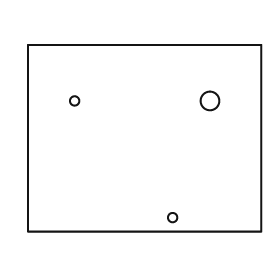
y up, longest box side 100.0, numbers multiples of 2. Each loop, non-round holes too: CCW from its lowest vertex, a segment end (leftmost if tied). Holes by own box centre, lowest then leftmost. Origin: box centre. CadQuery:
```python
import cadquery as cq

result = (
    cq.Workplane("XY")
    .moveTo(-50.0, -40.0)
    .lineTo(50.0, -40.0)
    .lineTo(50.0, 40.0)
    .lineTo(-50.0, 40.0)
    .close()
    .moveTo(12.0, -34.0)
    .circle(2.0)
    .moveTo(-30.0, 16.0)
    .circle(2.0)
    .moveTo(28.0, 16.0)
    .circle(4.0)
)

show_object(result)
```